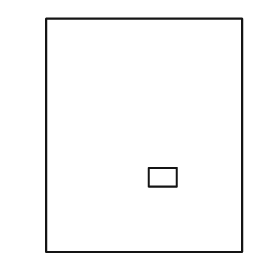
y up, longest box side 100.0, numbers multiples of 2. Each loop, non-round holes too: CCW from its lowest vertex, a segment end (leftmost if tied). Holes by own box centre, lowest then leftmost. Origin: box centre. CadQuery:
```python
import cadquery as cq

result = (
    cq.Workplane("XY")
    .moveTo(-42.0, -50.0)
    .lineTo(42.0, -50.0)
    .lineTo(42.0, 50.0)
    .lineTo(-42.0, 50.0)
    .close()
    .moveTo(2.0, -22.0)
    .lineTo(14.0, -22.0)
    .lineTo(14.0, -14.0)
    .lineTo(2.0, -14.0)
    .close()
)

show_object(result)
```